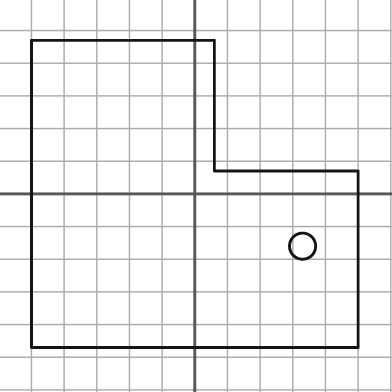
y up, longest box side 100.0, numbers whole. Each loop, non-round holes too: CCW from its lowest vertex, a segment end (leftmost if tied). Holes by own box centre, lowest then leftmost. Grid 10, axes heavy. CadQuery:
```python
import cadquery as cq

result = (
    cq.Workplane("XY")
    .moveTo(-50.0, -47.0)
    .lineTo(50.0, -47.0)
    .lineTo(50.0, 7.0)
    .lineTo(6.0, 7.0)
    .lineTo(6.0, 47.0)
    .lineTo(-50.0, 47.0)
    .close()
    .moveTo(33.0, -16.0)
    .circle(4.0)
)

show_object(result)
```